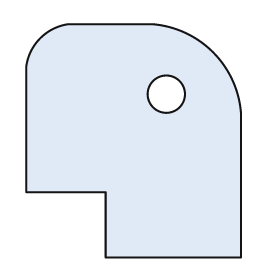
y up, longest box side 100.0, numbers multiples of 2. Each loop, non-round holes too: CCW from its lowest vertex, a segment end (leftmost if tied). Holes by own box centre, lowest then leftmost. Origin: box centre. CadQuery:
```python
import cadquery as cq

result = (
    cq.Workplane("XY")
    .moveTo(-12.0, -50.0)
    .lineTo(46.0, -50.0)
    .lineTo(46.0, 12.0)
    .threePointArc((34.0, 38.0), (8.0, 50.0))
    .lineTo(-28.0, 50.0)
    .threePointArc((-40.0, 44.0), (-46.0, 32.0))
    .lineTo(-46.0, -22.0)
    .lineTo(-12.0, -22.0)
    .close()
    .moveTo(14.0, 20.0)
    .circle(8.0)
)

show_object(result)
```